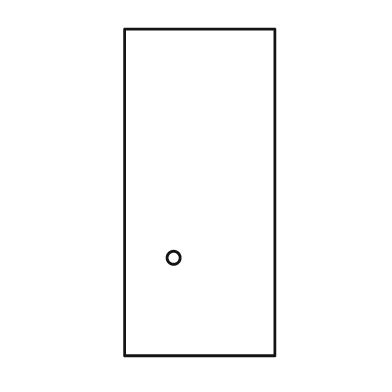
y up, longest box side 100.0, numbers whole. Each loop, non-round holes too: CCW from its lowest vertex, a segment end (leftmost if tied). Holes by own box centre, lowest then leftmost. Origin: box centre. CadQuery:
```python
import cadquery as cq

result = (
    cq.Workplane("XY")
    .moveTo(-23.0, -50.0)
    .lineTo(23.0, -50.0)
    .lineTo(23.0, 50.0)
    .lineTo(-23.0, 50.0)
    .close()
    .moveTo(-8.0, -20.0)
    .circle(2.0)
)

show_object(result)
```